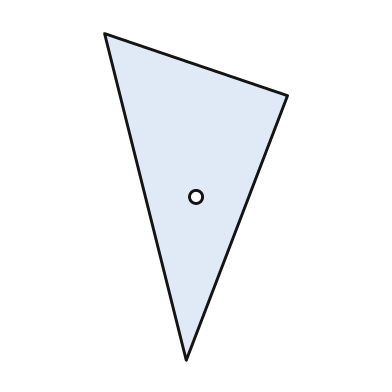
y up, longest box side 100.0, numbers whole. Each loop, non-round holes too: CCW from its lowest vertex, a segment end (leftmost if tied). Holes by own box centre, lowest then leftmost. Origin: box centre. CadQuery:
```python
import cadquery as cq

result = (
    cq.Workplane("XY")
    .moveTo(-3.0, -50.0)
    .lineTo(28.0, 31.0)
    .lineTo(-28.0, 50.0)
    .close()
    .moveTo(0.0, 0.0)
    .circle(2.0)
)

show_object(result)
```